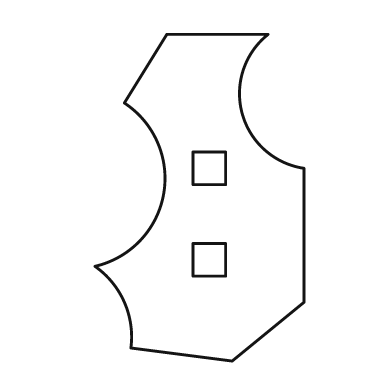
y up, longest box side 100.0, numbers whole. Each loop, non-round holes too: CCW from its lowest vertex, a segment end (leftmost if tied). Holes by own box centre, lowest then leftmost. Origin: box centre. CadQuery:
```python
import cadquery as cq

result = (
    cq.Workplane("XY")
    .moveTo(10.0, -50.0)
    .lineTo(32.0, -32.0)
    .lineTo(32.0, 9.0)
    .threePointArc((13.0, 26.0), (21.0, 50.0))
    .lineTo(-10.0, 50.0)
    .lineTo(-23.0, 29.0)
    .threePointArc((-11.0, 1.0), (-32.0, -21.0))
    .threePointArc((-23.0, -32.0), (-21.0, -46.0))
    .close()
    .moveTo(-2.0, -24.0)
    .lineTo(8.0, -24.0)
    .lineTo(8.0, -14.0)
    .lineTo(-2.0, -14.0)
    .close()
    .moveTo(-2.0, 4.0)
    .lineTo(8.0, 4.0)
    .lineTo(8.0, 14.0)
    .lineTo(-2.0, 14.0)
    .close()
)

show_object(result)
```